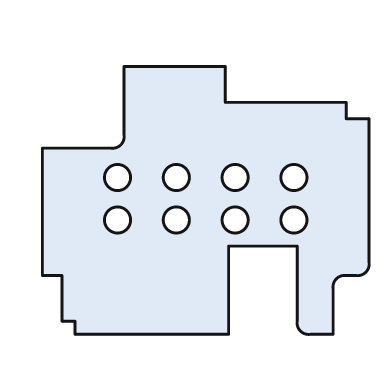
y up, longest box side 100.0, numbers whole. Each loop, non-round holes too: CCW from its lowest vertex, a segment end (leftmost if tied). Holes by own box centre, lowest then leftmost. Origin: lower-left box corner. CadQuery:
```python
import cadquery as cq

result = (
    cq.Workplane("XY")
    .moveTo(10.0, 0.0)
    .lineTo(57.0, 0.0)
    .lineTo(57.0, 27.0)
    .lineTo(78.0, 27.0)
    .lineTo(78.0, 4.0)
    .threePointArc((79.0, 1.0), (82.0, 0.0))
    .lineTo(89.0, 0.0)
    .lineTo(89.0, 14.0)
    .threePointArc((90.0, 17.0), (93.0, 18.0))
    .lineTo(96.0, 18.0)
    .threePointArc((99.0, 19.0), (100.0, 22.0))
    .lineTo(100.0, 66.0)
    .lineTo(93.0, 66.0)
    .lineTo(93.0, 71.0)
    .lineTo(56.0, 71.0)
    .lineTo(56.0, 82.0)
    .lineTo(25.0, 82.0)
    .lineTo(25.0, 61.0)
    .threePointArc((24.0, 58.0), (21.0, 57.0))
    .lineTo(0.0, 57.0)
    .lineTo(0.0, 18.0)
    .lineTo(6.0, 18.0)
    .lineTo(6.0, 4.0)
    .lineTo(10.0, 4.0)
    .close()
    .moveTo(23.0, 35.0)
    .circle(4.0)
    .moveTo(41.0, 35.0)
    .circle(4.0)
    .moveTo(59.0, 35.0)
    .circle(4.0)
    .moveTo(77.0, 35.0)
    .circle(4.0)
    .moveTo(23.0, 48.0)
    .circle(4.0)
    .moveTo(41.0, 48.0)
    .circle(4.0)
    .moveTo(59.0, 48.0)
    .circle(4.0)
    .moveTo(77.0, 48.0)
    .circle(4.0)
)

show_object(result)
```